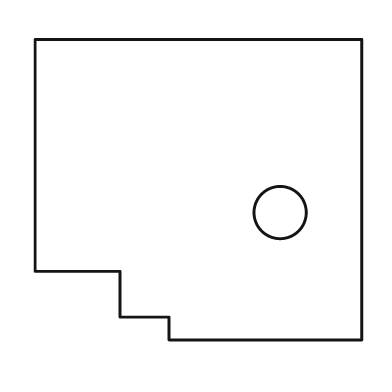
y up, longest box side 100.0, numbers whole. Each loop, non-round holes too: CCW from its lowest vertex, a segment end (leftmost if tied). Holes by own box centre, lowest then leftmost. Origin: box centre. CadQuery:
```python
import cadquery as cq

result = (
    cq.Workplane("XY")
    .moveTo(-9.0, -46.0)
    .lineTo(50.0, -46.0)
    .lineTo(50.0, 46.0)
    .lineTo(-50.0, 46.0)
    .lineTo(-50.0, -25.0)
    .lineTo(-24.0, -25.0)
    .lineTo(-24.0, -39.0)
    .lineTo(-9.0, -39.0)
    .close()
    .moveTo(25.0, -7.0)
    .circle(8.0)
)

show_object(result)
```